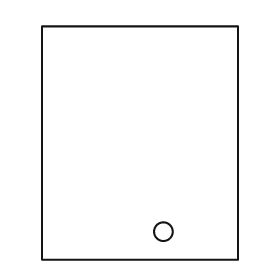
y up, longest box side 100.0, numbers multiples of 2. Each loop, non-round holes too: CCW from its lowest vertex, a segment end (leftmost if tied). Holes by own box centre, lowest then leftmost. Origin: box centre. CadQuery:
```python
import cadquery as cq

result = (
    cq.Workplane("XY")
    .moveTo(-42.0, -50.0)
    .lineTo(42.0, -50.0)
    .lineTo(42.0, 50.0)
    .lineTo(-42.0, 50.0)
    .close()
    .moveTo(10.0, -38.0)
    .circle(4.0)
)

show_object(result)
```